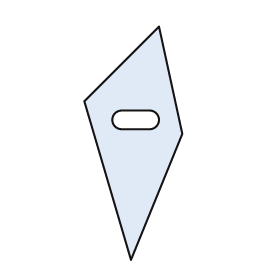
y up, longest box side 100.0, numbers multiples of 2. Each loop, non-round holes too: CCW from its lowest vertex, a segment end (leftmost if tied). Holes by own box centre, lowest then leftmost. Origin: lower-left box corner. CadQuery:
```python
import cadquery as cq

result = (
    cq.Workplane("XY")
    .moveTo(20.0, 0.0)
    .lineTo(42.0, 54.0)
    .lineTo(32.0, 100.0)
    .lineTo(0.0, 68.0)
    .close()
    .moveTo(16.0, 56.0)
    .lineTo(28.0, 56.0)
    .threePointArc((32.0, 60.0), (28.0, 64.0))
    .lineTo(16.0, 64.0)
    .threePointArc((12.0, 60.0), (16.0, 56.0))
    .close()
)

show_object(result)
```